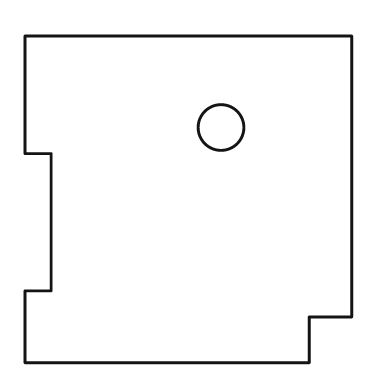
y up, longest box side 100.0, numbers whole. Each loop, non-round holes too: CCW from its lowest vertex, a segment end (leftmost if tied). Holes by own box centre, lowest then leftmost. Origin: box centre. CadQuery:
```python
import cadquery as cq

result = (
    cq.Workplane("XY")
    .moveTo(-50.0, -50.0)
    .lineTo(37.0, -50.0)
    .lineTo(37.0, -36.0)
    .lineTo(50.0, -36.0)
    .lineTo(50.0, 50.0)
    .lineTo(-50.0, 50.0)
    .lineTo(-50.0, 14.0)
    .lineTo(-42.0, 14.0)
    .lineTo(-42.0, -28.0)
    .lineTo(-50.0, -28.0)
    .close()
    .moveTo(10.0, 22.0)
    .circle(7.0)
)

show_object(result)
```